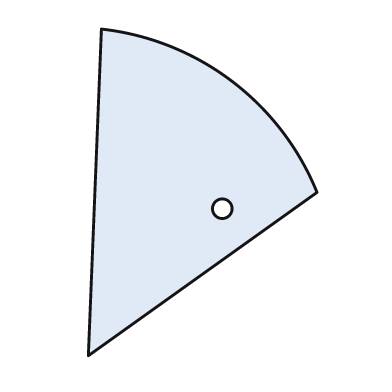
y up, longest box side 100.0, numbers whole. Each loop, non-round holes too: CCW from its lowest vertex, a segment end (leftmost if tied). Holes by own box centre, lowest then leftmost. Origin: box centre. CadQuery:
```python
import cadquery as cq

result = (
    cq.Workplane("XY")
    .moveTo(-35.0, -50.0)
    .lineTo(35.0, 0.0)
    .threePointArc((9.0, 34.0), (-31.0, 50.0))
    .close()
    .moveTo(6.0, -5.0)
    .circle(3.0)
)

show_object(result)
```